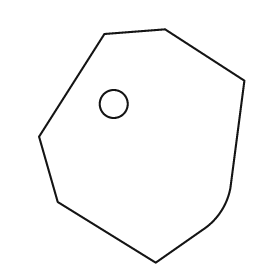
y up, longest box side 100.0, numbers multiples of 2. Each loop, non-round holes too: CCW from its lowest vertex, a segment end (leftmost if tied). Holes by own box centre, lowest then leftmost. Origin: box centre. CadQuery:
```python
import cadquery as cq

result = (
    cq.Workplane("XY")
    .moveTo(6.0, -50.0)
    .lineTo(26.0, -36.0)
    .threePointArc((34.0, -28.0), (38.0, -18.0))
    .lineTo(44.0, 28.0)
    .lineTo(10.0, 50.0)
    .lineTo(-16.0, 48.0)
    .lineTo(-44.0, 4.0)
    .lineTo(-36.0, -24.0)
    .close()
    .moveTo(-12.0, 18.0)
    .circle(6.0)
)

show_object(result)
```